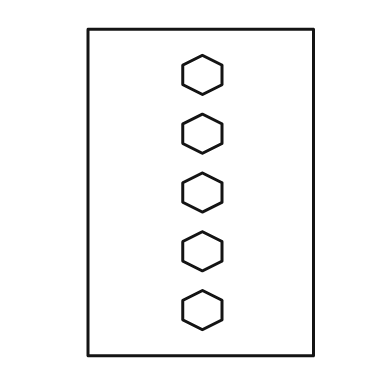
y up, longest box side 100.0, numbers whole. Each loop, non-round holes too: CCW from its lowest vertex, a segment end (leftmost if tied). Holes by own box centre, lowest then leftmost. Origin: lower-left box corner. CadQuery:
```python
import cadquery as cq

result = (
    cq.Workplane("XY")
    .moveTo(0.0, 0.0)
    .lineTo(69.0, 0.0)
    .lineTo(69.0, 100.0)
    .lineTo(0.0, 100.0)
    .close()
    .moveTo(35.0, 8.0)
    .lineTo(41.0, 11.0)
    .lineTo(41.0, 17.0)
    .lineTo(35.0, 20.0)
    .lineTo(29.0, 17.0)
    .lineTo(29.0, 11.0)
    .close()
    .moveTo(35.0, 26.0)
    .lineTo(41.0, 29.0)
    .lineTo(41.0, 35.0)
    .lineTo(35.0, 38.0)
    .lineTo(29.0, 35.0)
    .lineTo(29.0, 29.0)
    .close()
    .moveTo(35.0, 44.0)
    .lineTo(41.0, 47.0)
    .lineTo(41.0, 53.0)
    .lineTo(35.0, 56.0)
    .lineTo(29.0, 53.0)
    .lineTo(29.0, 47.0)
    .close()
    .moveTo(35.0, 62.0)
    .lineTo(41.0, 65.0)
    .lineTo(41.0, 71.0)
    .lineTo(35.0, 74.0)
    .lineTo(29.0, 71.0)
    .lineTo(29.0, 65.0)
    .close()
    .moveTo(35.0, 80.0)
    .lineTo(41.0, 83.0)
    .lineTo(41.0, 89.0)
    .lineTo(35.0, 92.0)
    .lineTo(29.0, 89.0)
    .lineTo(29.0, 83.0)
    .close()
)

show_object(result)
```